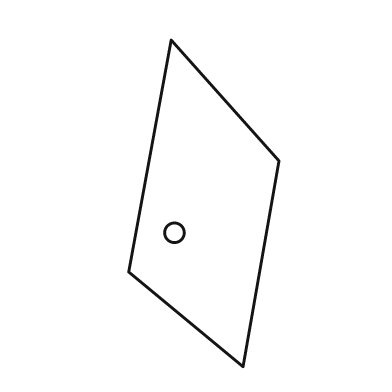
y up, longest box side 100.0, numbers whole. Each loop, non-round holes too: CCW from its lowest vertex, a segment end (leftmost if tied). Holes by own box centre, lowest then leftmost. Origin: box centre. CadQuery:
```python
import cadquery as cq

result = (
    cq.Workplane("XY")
    .moveTo(12.0, -50.0)
    .lineTo(23.0, 13.0)
    .lineTo(-10.0, 50.0)
    .lineTo(-23.0, -21.0)
    .close()
    .moveTo(-9.0, -9.0)
    .circle(3.0)
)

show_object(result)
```